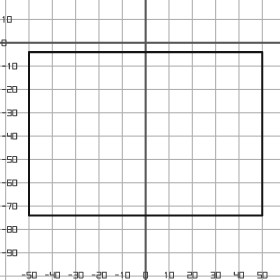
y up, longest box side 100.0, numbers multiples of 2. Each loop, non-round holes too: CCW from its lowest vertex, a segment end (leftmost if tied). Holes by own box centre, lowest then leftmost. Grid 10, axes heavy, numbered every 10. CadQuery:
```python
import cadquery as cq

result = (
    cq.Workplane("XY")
    .moveTo(-50.0, -74.0)
    .lineTo(50.0, -74.0)
    .lineTo(50.0, -4.0)
    .lineTo(-50.0, -4.0)
    .close()
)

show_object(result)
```